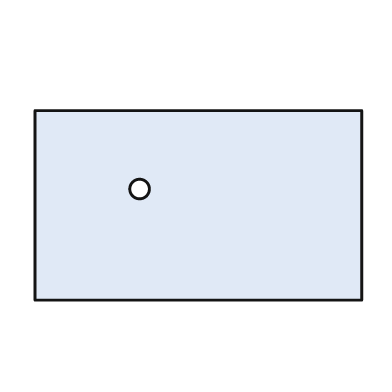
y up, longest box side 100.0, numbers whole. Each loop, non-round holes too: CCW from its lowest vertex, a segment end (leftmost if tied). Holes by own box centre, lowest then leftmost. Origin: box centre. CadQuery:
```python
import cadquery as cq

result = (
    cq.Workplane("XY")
    .moveTo(-50.0, -29.0)
    .lineTo(50.0, -29.0)
    .lineTo(50.0, 29.0)
    .lineTo(-50.0, 29.0)
    .close()
    .moveTo(-18.0, 5.0)
    .circle(3.0)
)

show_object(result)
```